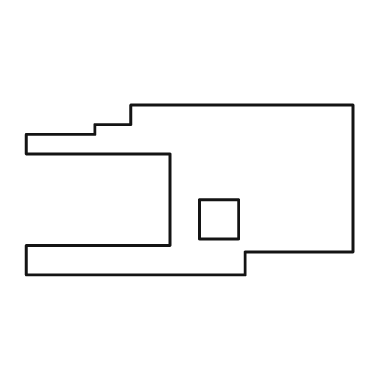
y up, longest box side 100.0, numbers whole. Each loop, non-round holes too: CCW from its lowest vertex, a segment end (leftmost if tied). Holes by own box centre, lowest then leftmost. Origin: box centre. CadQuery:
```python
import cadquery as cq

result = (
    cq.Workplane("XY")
    .moveTo(-50.0, -26.0)
    .lineTo(17.0, -26.0)
    .lineTo(17.0, -19.0)
    .lineTo(50.0, -19.0)
    .lineTo(50.0, 26.0)
    .lineTo(-18.0, 26.0)
    .lineTo(-18.0, 20.0)
    .lineTo(-29.0, 20.0)
    .lineTo(-29.0, 17.0)
    .lineTo(-50.0, 17.0)
    .lineTo(-50.0, 11.0)
    .lineTo(-6.0, 11.0)
    .lineTo(-6.0, -17.0)
    .lineTo(-50.0, -17.0)
    .close()
    .moveTo(3.0, -15.0)
    .lineTo(15.0, -15.0)
    .lineTo(15.0, -3.0)
    .lineTo(3.0, -3.0)
    .close()
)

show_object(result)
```